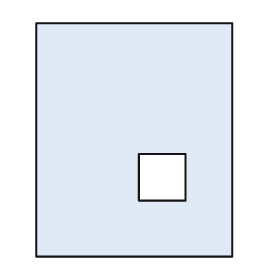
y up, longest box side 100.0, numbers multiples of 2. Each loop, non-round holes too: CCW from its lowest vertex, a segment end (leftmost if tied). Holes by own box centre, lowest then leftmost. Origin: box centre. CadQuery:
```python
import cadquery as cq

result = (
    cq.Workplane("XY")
    .moveTo(-42.0, -50.0)
    .lineTo(42.0, -50.0)
    .lineTo(42.0, 50.0)
    .lineTo(-42.0, 50.0)
    .close()
    .moveTo(2.0, -26.0)
    .lineTo(22.0, -26.0)
    .lineTo(22.0, -6.0)
    .lineTo(2.0, -6.0)
    .close()
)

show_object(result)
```